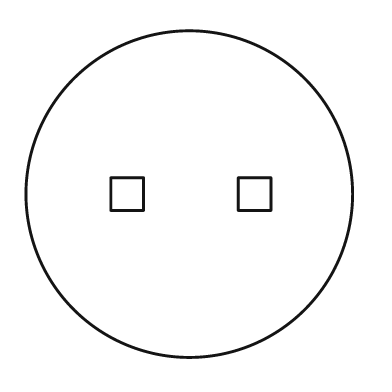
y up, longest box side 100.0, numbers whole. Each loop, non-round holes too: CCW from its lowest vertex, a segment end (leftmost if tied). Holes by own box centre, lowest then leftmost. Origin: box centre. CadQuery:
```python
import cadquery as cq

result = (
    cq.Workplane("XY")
    .moveTo(0.0, 0.0)
    .circle(50.0)
    .moveTo(-24.0, -5.0)
    .lineTo(-14.0, -5.0)
    .lineTo(-14.0, 5.0)
    .lineTo(-24.0, 5.0)
    .close()
    .moveTo(15.0, -5.0)
    .lineTo(25.0, -5.0)
    .lineTo(25.0, 5.0)
    .lineTo(15.0, 5.0)
    .close()
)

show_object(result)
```